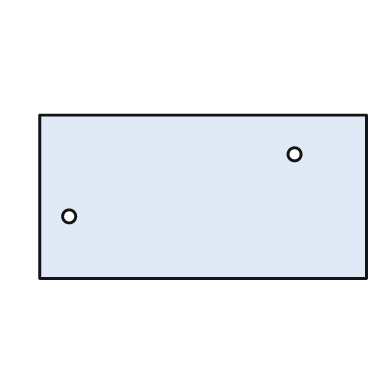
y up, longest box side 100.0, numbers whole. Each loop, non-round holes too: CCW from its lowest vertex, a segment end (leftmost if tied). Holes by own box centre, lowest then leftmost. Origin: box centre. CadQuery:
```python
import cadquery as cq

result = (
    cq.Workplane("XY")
    .moveTo(-50.0, -25.0)
    .lineTo(50.0, -25.0)
    .lineTo(50.0, 25.0)
    .lineTo(-50.0, 25.0)
    .close()
    .moveTo(-41.0, -6.0)
    .circle(2.0)
    .moveTo(28.0, 13.0)
    .circle(2.0)
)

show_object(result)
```